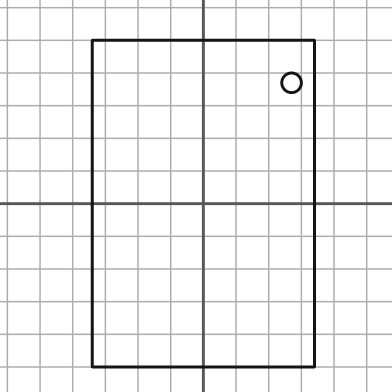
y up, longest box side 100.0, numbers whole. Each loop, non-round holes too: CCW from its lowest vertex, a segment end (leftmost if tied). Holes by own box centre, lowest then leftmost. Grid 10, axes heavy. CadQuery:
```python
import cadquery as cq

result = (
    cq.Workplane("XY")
    .moveTo(-34.0, -50.0)
    .lineTo(34.0, -50.0)
    .lineTo(34.0, 50.0)
    .lineTo(-34.0, 50.0)
    .close()
    .moveTo(27.0, 37.0)
    .circle(3.0)
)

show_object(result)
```